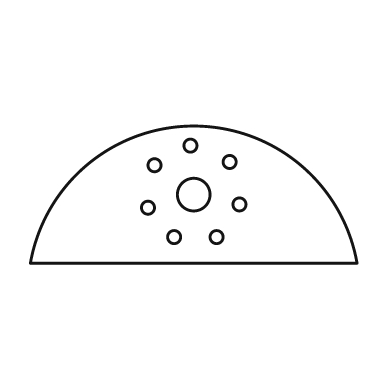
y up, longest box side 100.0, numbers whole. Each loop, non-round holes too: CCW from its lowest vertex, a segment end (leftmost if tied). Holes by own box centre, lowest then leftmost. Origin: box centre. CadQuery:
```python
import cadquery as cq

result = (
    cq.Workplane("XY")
    .moveTo(-50.0, -21.0)
    .lineTo(50.0, -21.0)
    .threePointArc((0.0, 21.0), (-50.0, -21.0))
    .close()
    .moveTo(-6.0, -13.0)
    .circle(2.0)
    .moveTo(7.0, -13.0)
    .circle(2.0)
    .moveTo(-14.0, -4.0)
    .circle(2.0)
    .moveTo(14.0, -3.0)
    .circle(2.0)
    .moveTo(0.0, 0.0)
    .circle(5.0)
    .moveTo(-12.0, 9.0)
    .circle(2.0)
    .moveTo(11.0, 10.0)
    .circle(2.0)
    .moveTo(-1.0, 15.0)
    .circle(2.0)
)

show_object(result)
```